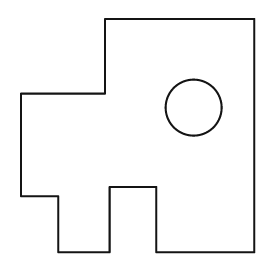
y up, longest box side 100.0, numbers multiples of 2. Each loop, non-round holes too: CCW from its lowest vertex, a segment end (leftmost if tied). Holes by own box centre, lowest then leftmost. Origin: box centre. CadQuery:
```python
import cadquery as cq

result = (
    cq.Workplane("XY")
    .moveTo(-34.0, -50.0)
    .lineTo(-12.0, -50.0)
    .lineTo(-12.0, -22.0)
    .lineTo(8.0, -22.0)
    .lineTo(8.0, -50.0)
    .lineTo(50.0, -50.0)
    .lineTo(50.0, 50.0)
    .lineTo(-14.0, 50.0)
    .lineTo(-14.0, 18.0)
    .lineTo(-50.0, 18.0)
    .lineTo(-50.0, -26.0)
    .lineTo(-34.0, -26.0)
    .close()
    .moveTo(24.0, 12.0)
    .circle(12.0)
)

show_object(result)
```